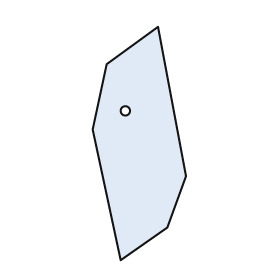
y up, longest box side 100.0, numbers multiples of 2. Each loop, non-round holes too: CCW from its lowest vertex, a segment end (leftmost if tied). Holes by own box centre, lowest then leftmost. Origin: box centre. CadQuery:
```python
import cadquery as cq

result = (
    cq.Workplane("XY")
    .moveTo(-8.0, -50.0)
    .lineTo(12.0, -36.0)
    .lineTo(20.0, -14.0)
    .lineTo(8.0, 50.0)
    .lineTo(-14.0, 34.0)
    .lineTo(-20.0, 6.0)
    .close()
    .moveTo(-6.0, 14.0)
    .circle(2.0)
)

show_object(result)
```